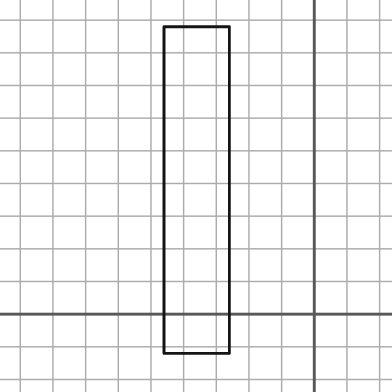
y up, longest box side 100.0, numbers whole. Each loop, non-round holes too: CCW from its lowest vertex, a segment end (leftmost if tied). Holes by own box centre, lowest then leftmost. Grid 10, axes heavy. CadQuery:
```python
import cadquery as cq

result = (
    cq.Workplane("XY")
    .moveTo(-46.0, -12.0)
    .lineTo(-26.0, -12.0)
    .lineTo(-26.0, 88.0)
    .lineTo(-46.0, 88.0)
    .close()
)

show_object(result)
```